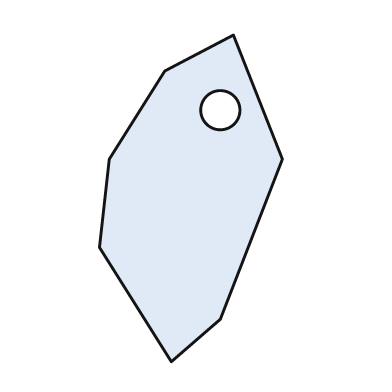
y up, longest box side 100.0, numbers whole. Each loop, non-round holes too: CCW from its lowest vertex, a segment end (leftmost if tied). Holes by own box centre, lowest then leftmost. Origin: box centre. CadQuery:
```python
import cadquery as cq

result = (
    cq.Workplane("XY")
    .moveTo(-6.0, -50.0)
    .lineTo(9.0, -37.0)
    .lineTo(28.0, 12.0)
    .lineTo(13.0, 50.0)
    .lineTo(-8.0, 39.0)
    .lineTo(-25.0, 12.0)
    .lineTo(-28.0, -15.0)
    .close()
    .moveTo(9.0, 27.0)
    .circle(6.0)
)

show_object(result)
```